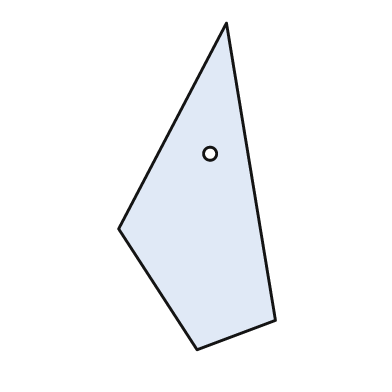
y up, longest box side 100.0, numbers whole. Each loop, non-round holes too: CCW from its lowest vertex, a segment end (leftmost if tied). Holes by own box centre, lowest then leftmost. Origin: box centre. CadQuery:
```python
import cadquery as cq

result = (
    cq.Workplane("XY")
    .moveTo(0.0, -50.0)
    .lineTo(24.0, -41.0)
    .lineTo(9.0, 50.0)
    .lineTo(-24.0, -13.0)
    .close()
    .moveTo(4.0, 10.0)
    .circle(2.0)
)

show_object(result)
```